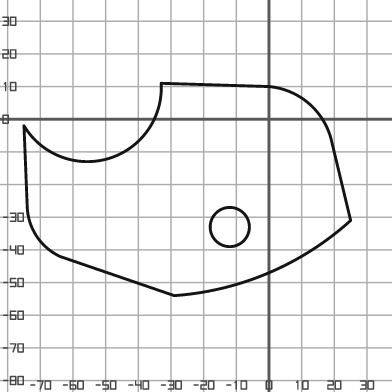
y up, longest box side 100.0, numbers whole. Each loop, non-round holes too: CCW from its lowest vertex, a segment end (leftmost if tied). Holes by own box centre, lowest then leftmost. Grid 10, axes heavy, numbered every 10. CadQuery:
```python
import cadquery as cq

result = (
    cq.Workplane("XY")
    .moveTo(-29.0, -54.0)
    .threePointArc((0.0, -47.0), (25.0, -31.0))
    .lineTo(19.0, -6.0)
    .threePointArc((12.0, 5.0), (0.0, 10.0))
    .lineTo(-33.0, 11.0)
    .threePointArc((-49.0, -12.0), (-75.0, -2.0))
    .lineTo(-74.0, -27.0)
    .threePointArc((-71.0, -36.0), (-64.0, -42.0))
    .close()
    .moveTo(-12.0, -33.0)
    .circle(6.0)
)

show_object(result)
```